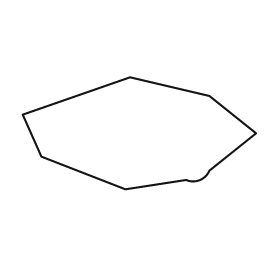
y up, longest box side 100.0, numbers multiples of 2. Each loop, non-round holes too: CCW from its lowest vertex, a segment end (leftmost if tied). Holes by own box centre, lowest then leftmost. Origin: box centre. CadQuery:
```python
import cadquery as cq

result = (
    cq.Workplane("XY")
    .moveTo(-6.0, -24.0)
    .lineTo(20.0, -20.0)
    .threePointArc((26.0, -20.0), (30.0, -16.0))
    .lineTo(50.0, 0.0)
    .lineTo(30.0, 16.0)
    .lineTo(-4.0, 24.0)
    .lineTo(-50.0, 8.0)
    .lineTo(-42.0, -10.0)
    .close()
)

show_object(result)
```